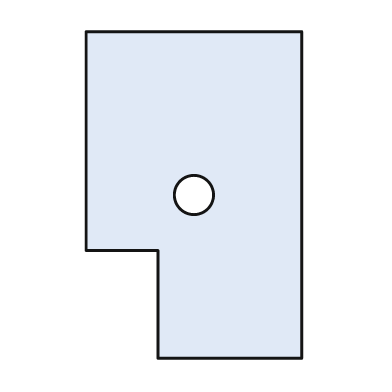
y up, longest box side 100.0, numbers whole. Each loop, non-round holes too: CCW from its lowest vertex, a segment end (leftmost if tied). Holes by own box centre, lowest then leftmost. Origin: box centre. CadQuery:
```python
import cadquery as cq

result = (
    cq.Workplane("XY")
    .moveTo(-11.0, -50.0)
    .lineTo(33.0, -50.0)
    .lineTo(33.0, 50.0)
    .lineTo(-33.0, 50.0)
    .lineTo(-33.0, -17.0)
    .lineTo(-11.0, -17.0)
    .close()
    .moveTo(0.0, 0.0)
    .circle(6.0)
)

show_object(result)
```